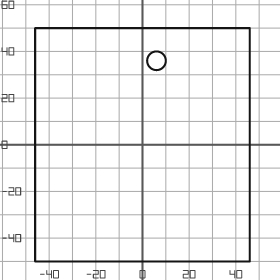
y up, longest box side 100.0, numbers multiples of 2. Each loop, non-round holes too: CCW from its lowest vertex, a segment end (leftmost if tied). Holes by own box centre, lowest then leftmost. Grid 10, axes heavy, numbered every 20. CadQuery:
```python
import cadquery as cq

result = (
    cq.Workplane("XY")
    .moveTo(-46.0, -50.0)
    .lineTo(46.0, -50.0)
    .lineTo(46.0, 50.0)
    .lineTo(-46.0, 50.0)
    .close()
    .moveTo(6.0, 36.0)
    .circle(4.0)
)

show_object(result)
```